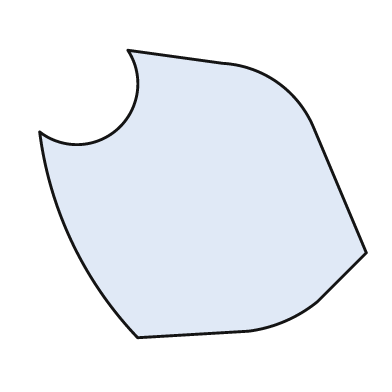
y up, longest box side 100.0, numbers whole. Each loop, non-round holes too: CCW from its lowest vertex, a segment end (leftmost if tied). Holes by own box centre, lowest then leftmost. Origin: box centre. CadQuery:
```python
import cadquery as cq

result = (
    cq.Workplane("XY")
    .moveTo(-20.0, -44.0)
    .lineTo(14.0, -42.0)
    .threePointArc((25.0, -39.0), (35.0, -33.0))
    .lineTo(50.0, -18.0)
    .lineTo(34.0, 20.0)
    .threePointArc((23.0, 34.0), (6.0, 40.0))
    .lineTo(-23.0, 44.0)
    .threePointArc((-26.0, 20.0), (-50.0, 19.0))
    .threePointArc((-40.0, -15.0), (-20.0, -44.0))
    .close()
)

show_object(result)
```